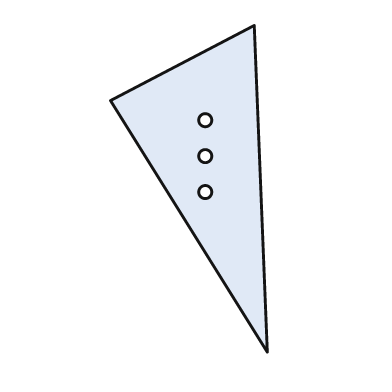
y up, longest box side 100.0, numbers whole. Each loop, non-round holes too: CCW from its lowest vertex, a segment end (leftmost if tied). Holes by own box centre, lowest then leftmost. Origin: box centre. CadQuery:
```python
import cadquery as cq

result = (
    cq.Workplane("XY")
    .moveTo(24.0, -50.0)
    .lineTo(20.0, 50.0)
    .lineTo(-24.0, 27.0)
    .close()
    .moveTo(5.0, -1.0)
    .circle(2.0)
    .moveTo(5.0, 10.0)
    .circle(2.0)
    .moveTo(5.0, 21.0)
    .circle(2.0)
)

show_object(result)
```